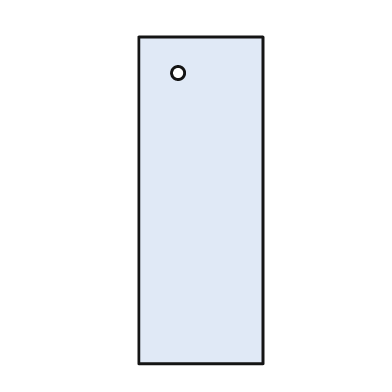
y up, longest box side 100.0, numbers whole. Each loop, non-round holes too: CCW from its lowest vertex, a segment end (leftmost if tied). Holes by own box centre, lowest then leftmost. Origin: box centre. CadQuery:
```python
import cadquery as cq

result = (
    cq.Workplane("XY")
    .moveTo(-19.0, -50.0)
    .lineTo(19.0, -50.0)
    .lineTo(19.0, 50.0)
    .lineTo(-19.0, 50.0)
    .close()
    .moveTo(-7.0, 39.0)
    .circle(2.0)
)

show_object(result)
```